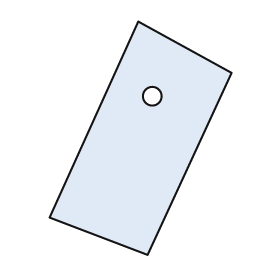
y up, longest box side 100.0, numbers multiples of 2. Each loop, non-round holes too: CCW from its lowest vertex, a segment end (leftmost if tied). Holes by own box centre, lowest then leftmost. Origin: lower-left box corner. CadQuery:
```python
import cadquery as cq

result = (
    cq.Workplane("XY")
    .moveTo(42.0, 0.0)
    .lineTo(78.0, 78.0)
    .lineTo(38.0, 100.0)
    .lineTo(0.0, 16.0)
    .close()
    .moveTo(44.0, 68.0)
    .circle(4.0)
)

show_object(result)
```